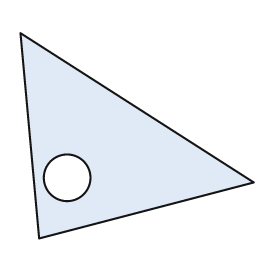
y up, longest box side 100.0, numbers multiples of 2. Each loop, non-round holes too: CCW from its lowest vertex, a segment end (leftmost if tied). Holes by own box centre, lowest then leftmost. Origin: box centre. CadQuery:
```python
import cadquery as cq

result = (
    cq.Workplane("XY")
    .moveTo(-42.0, -44.0)
    .lineTo(50.0, -20.0)
    .lineTo(-50.0, 44.0)
    .close()
    .moveTo(-30.0, -18.0)
    .circle(10.0)
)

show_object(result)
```